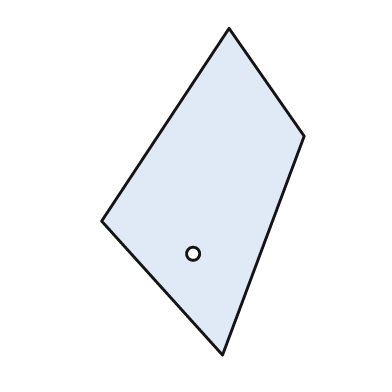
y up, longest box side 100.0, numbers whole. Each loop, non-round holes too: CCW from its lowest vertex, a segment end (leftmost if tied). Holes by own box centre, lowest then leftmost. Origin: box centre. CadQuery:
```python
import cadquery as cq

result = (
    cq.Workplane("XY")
    .moveTo(6.0, -50.0)
    .lineTo(31.0, 17.0)
    .lineTo(8.0, 50.0)
    .lineTo(-31.0, -9.0)
    .close()
    .moveTo(-3.0, -19.0)
    .circle(2.0)
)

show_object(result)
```